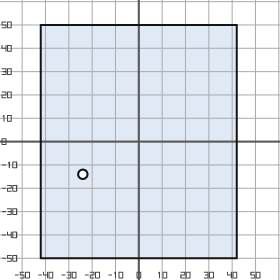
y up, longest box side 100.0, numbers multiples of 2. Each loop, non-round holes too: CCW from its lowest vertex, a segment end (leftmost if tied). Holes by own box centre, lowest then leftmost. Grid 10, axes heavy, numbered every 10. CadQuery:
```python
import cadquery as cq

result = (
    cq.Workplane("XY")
    .moveTo(-42.0, -50.0)
    .lineTo(42.0, -50.0)
    .lineTo(42.0, 50.0)
    .lineTo(-42.0, 50.0)
    .close()
    .moveTo(-24.0, -14.0)
    .circle(2.0)
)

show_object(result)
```